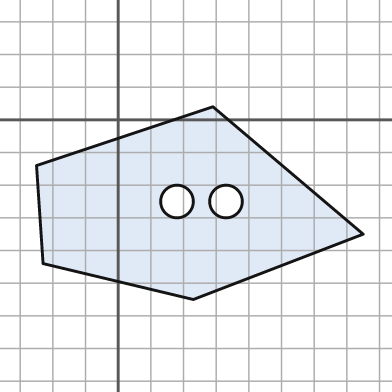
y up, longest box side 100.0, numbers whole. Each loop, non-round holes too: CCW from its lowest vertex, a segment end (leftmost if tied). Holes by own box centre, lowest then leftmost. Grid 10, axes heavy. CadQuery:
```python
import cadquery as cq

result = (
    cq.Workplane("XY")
    .moveTo(23.0, -55.0)
    .lineTo(75.0, -35.0)
    .lineTo(29.0, 4.0)
    .lineTo(-25.0, -14.0)
    .lineTo(-23.0, -44.0)
    .close()
    .moveTo(18.0, -25.0)
    .circle(5.0)
    .moveTo(33.0, -25.0)
    .circle(5.0)
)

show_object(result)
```